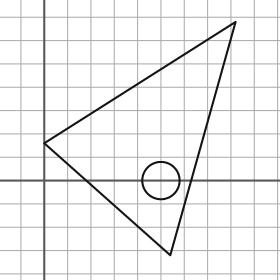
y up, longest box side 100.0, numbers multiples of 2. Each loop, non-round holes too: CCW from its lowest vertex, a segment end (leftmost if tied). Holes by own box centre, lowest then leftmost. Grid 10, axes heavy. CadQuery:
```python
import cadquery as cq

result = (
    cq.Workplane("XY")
    .moveTo(54.0, -32.0)
    .lineTo(82.0, 68.0)
    .lineTo(0.0, 16.0)
    .close()
    .moveTo(50.0, 0.0)
    .circle(8.0)
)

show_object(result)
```